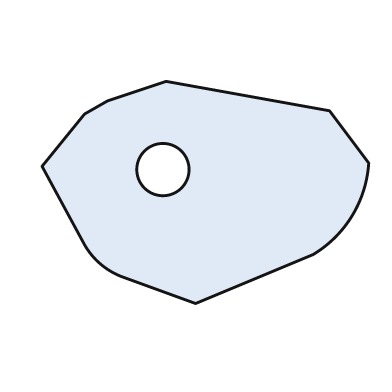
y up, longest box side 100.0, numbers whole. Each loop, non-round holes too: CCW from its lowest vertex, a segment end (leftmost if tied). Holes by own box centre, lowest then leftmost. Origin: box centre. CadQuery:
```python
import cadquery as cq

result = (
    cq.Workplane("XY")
    .moveTo(-3.0, -34.0)
    .lineTo(33.0, -19.0)
    .threePointArc((45.0, -7.0), (50.0, 9.0))
    .lineTo(38.0, 25.0)
    .lineTo(-12.0, 34.0)
    .lineTo(-30.0, 28.0)
    .lineTo(-37.0, 24.0)
    .lineTo(-50.0, 8.0)
    .lineTo(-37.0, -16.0)
    .threePointArc((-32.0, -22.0), (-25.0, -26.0))
    .close()
    .moveTo(-13.0, 7.0)
    .circle(8.0)
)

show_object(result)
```